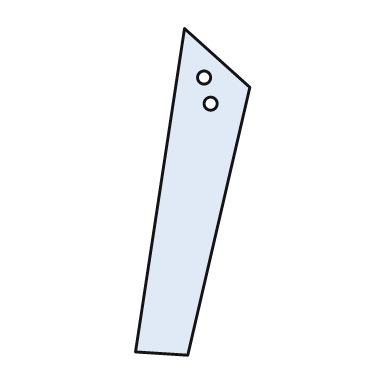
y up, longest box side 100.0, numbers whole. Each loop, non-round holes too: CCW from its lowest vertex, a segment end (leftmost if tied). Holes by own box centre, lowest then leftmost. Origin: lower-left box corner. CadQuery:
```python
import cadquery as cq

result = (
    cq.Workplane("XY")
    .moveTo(16.0, 0.0)
    .lineTo(35.0, 82.0)
    .lineTo(15.0, 100.0)
    .lineTo(0.0, 1.0)
    .close()
    .moveTo(23.0, 77.0)
    .circle(2.0)
    .moveTo(21.0, 85.0)
    .circle(2.0)
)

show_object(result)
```